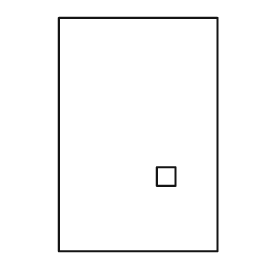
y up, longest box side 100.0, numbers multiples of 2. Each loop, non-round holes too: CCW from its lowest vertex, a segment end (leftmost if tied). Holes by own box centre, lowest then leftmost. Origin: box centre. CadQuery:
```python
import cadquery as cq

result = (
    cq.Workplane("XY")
    .moveTo(-34.0, -50.0)
    .lineTo(34.0, -50.0)
    .lineTo(34.0, 50.0)
    .lineTo(-34.0, 50.0)
    .close()
    .moveTo(8.0, -22.0)
    .lineTo(16.0, -22.0)
    .lineTo(16.0, -14.0)
    .lineTo(8.0, -14.0)
    .close()
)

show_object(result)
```